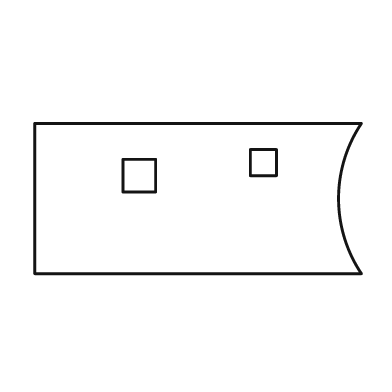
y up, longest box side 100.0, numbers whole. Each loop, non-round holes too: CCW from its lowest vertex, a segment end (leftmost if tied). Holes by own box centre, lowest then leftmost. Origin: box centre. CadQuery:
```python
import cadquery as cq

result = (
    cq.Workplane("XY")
    .moveTo(-50.0, -23.0)
    .lineTo(50.0, -23.0)
    .threePointArc((43.0, 0.0), (50.0, 23.0))
    .lineTo(-50.0, 23.0)
    .close()
    .moveTo(-23.0, 2.0)
    .lineTo(-13.0, 2.0)
    .lineTo(-13.0, 12.0)
    .lineTo(-23.0, 12.0)
    .close()
    .moveTo(16.0, 7.0)
    .lineTo(24.0, 7.0)
    .lineTo(24.0, 15.0)
    .lineTo(16.0, 15.0)
    .close()
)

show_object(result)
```